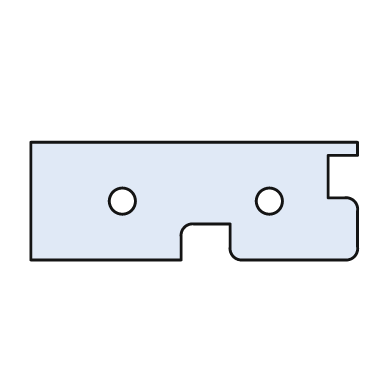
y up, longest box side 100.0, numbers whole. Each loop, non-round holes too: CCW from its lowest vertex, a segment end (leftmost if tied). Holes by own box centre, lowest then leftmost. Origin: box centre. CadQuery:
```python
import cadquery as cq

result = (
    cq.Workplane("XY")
    .moveTo(-50.0, -18.0)
    .lineTo(-4.0, -18.0)
    .lineTo(-4.0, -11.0)
    .threePointArc((-3.0, -8.0), (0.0, -7.0))
    .lineTo(11.0, -7.0)
    .lineTo(11.0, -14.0)
    .threePointArc((12.0, -17.0), (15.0, -18.0))
    .lineTo(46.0, -18.0)
    .threePointArc((49.0, -17.0), (50.0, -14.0))
    .lineTo(50.0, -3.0)
    .threePointArc((49.0, 0.0), (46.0, 1.0))
    .lineTo(41.0, 1.0)
    .lineTo(41.0, 14.0)
    .lineTo(50.0, 14.0)
    .lineTo(50.0, 18.0)
    .lineTo(-50.0, 18.0)
    .close()
    .moveTo(-22.0, 0.0)
    .circle(4.0)
    .moveTo(23.0, 0.0)
    .circle(4.0)
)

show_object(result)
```